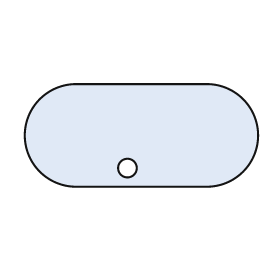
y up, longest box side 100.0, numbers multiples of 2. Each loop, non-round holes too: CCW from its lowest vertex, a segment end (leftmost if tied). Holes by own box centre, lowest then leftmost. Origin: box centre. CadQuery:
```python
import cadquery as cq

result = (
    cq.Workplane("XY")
    .moveTo(-28.0, -22.0)
    .lineTo(28.0, -22.0)
    .threePointArc((50.0, 0.0), (28.0, 22.0))
    .lineTo(-28.0, 22.0)
    .threePointArc((-50.0, 0.0), (-28.0, -22.0))
    .close()
    .moveTo(-6.0, -14.0)
    .circle(4.0)
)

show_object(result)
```